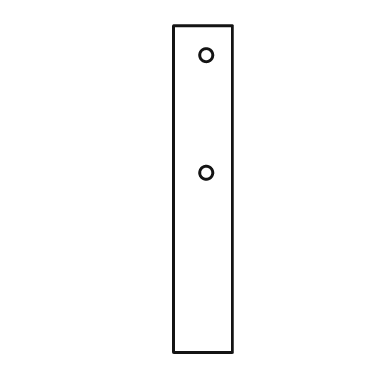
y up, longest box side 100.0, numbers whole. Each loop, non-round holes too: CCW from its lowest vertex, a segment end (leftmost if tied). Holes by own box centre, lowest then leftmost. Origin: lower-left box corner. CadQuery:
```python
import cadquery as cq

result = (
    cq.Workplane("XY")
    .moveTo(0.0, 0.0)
    .lineTo(18.0, 0.0)
    .lineTo(18.0, 100.0)
    .lineTo(0.0, 100.0)
    .close()
    .moveTo(10.0, 55.0)
    .circle(2.0)
    .moveTo(10.0, 91.0)
    .circle(2.0)
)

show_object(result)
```